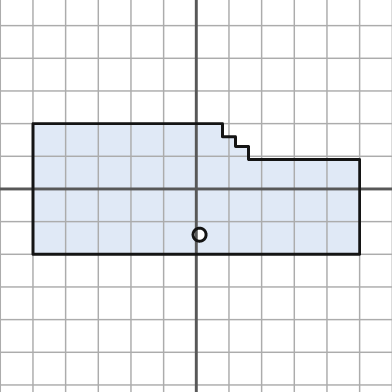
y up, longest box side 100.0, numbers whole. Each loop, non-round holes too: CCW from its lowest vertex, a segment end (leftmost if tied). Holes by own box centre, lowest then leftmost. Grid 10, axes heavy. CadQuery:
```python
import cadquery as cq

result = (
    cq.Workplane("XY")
    .moveTo(-50.0, -20.0)
    .lineTo(50.0, -20.0)
    .lineTo(50.0, 9.0)
    .lineTo(16.0, 9.0)
    .lineTo(16.0, 13.0)
    .lineTo(12.0, 13.0)
    .lineTo(12.0, 16.0)
    .lineTo(8.0, 16.0)
    .lineTo(8.0, 20.0)
    .lineTo(-50.0, 20.0)
    .close()
    .moveTo(1.0, -14.0)
    .circle(2.0)
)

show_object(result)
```